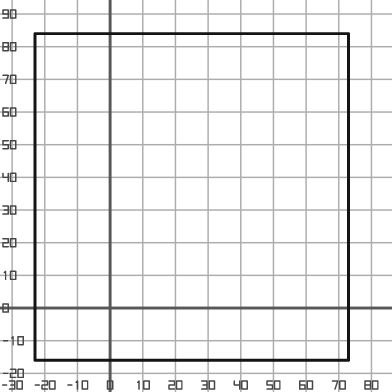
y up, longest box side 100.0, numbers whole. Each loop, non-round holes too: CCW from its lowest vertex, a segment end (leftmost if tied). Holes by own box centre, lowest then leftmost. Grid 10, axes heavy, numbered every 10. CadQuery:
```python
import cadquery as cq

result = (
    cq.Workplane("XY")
    .moveTo(-23.0, -16.0)
    .lineTo(73.0, -16.0)
    .lineTo(73.0, 84.0)
    .lineTo(-23.0, 84.0)
    .close()
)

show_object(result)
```